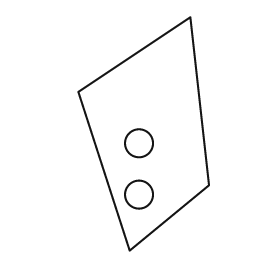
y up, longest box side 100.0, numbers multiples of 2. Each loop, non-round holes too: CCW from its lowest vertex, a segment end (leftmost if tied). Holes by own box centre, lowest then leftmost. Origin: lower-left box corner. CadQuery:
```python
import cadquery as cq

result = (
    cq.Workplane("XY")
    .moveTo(22.0, 0.0)
    .lineTo(56.0, 28.0)
    .lineTo(48.0, 100.0)
    .lineTo(0.0, 68.0)
    .close()
    .moveTo(26.0, 24.0)
    .circle(6.0)
    .moveTo(26.0, 46.0)
    .circle(6.0)
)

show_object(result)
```